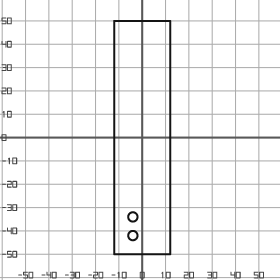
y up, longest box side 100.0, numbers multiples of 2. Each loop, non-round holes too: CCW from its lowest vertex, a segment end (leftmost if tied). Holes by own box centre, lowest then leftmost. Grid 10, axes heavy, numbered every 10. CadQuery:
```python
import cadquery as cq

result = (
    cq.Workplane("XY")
    .moveTo(-12.0, -50.0)
    .lineTo(12.0, -50.0)
    .lineTo(12.0, 50.0)
    .lineTo(-12.0, 50.0)
    .close()
    .moveTo(-4.0, -42.0)
    .circle(2.0)
    .moveTo(-4.0, -34.0)
    .circle(2.0)
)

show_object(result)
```